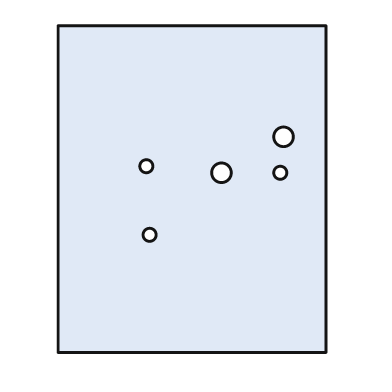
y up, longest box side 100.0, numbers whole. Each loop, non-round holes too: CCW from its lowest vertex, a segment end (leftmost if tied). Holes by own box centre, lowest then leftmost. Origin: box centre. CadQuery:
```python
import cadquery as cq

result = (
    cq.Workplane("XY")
    .moveTo(-41.0, -50.0)
    .lineTo(41.0, -50.0)
    .lineTo(41.0, 50.0)
    .lineTo(-41.0, 50.0)
    .close()
    .moveTo(-13.0, -14.0)
    .circle(2.0)
    .moveTo(9.0, 5.0)
    .circle(3.0)
    .moveTo(27.0, 5.0)
    .circle(2.0)
    .moveTo(-14.0, 7.0)
    .circle(2.0)
    .moveTo(28.0, 16.0)
    .circle(3.0)
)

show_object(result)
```